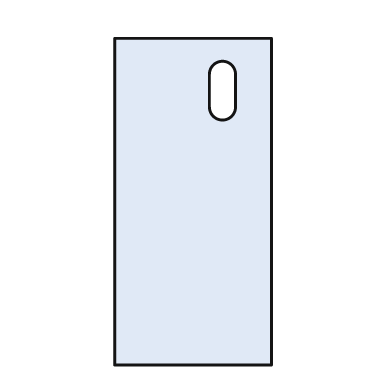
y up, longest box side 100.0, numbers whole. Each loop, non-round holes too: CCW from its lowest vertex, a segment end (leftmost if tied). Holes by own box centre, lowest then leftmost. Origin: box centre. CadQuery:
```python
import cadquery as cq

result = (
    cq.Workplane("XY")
    .moveTo(-24.0, -50.0)
    .lineTo(24.0, -50.0)
    .lineTo(24.0, 50.0)
    .lineTo(-24.0, 50.0)
    .close()
    .moveTo(5.0, 29.0)
    .threePointArc((9.0, 25.0), (13.0, 29.0))
    .lineTo(13.0, 39.0)
    .threePointArc((9.0, 43.0), (5.0, 39.0))
    .close()
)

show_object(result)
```